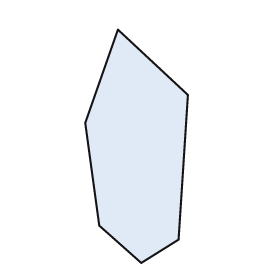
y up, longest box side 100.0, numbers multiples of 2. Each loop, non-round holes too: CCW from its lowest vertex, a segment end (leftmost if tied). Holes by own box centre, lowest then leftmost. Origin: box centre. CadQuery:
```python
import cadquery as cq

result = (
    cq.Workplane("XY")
    .moveTo(2.0, -50.0)
    .lineTo(18.0, -40.0)
    .lineTo(22.0, 22.0)
    .lineTo(-8.0, 50.0)
    .lineTo(-22.0, 10.0)
    .lineTo(-16.0, -34.0)
    .close()
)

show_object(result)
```